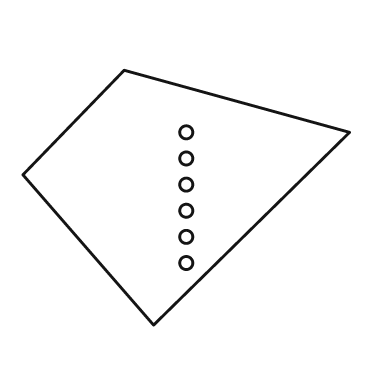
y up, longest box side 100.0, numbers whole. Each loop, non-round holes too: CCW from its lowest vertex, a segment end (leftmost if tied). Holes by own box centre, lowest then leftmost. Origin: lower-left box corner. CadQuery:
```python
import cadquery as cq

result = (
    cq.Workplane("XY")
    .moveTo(40.0, 0.0)
    .lineTo(100.0, 59.0)
    .lineTo(31.0, 78.0)
    .lineTo(0.0, 46.0)
    .close()
    .moveTo(50.0, 19.0)
    .circle(2.0)
    .moveTo(50.0, 27.0)
    .circle(2.0)
    .moveTo(50.0, 35.0)
    .circle(2.0)
    .moveTo(50.0, 43.0)
    .circle(2.0)
    .moveTo(50.0, 51.0)
    .circle(2.0)
    .moveTo(50.0, 59.0)
    .circle(2.0)
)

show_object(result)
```